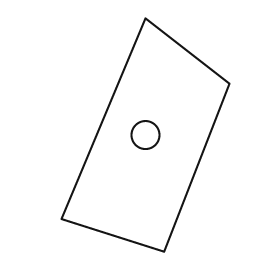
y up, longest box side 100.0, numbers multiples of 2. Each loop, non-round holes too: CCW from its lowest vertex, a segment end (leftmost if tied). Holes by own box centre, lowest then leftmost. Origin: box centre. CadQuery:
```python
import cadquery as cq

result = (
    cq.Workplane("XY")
    .moveTo(8.0, -50.0)
    .lineTo(36.0, 22.0)
    .lineTo(0.0, 50.0)
    .lineTo(-36.0, -36.0)
    .close()
    .moveTo(0.0, 0.0)
    .circle(6.0)
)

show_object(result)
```